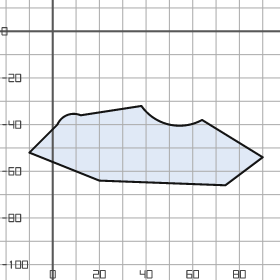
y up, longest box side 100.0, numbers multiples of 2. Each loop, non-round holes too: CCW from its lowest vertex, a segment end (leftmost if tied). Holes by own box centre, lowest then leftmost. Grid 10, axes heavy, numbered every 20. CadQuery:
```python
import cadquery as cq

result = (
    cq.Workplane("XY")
    .moveTo(74.0, -66.0)
    .lineTo(90.0, -54.0)
    .lineTo(64.0, -38.0)
    .threePointArc((50.0, -40.0), (38.0, -32.0))
    .lineTo(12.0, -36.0)
    .threePointArc((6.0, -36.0), (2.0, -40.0))
    .lineTo(-10.0, -52.0)
    .lineTo(20.0, -64.0)
    .close()
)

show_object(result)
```